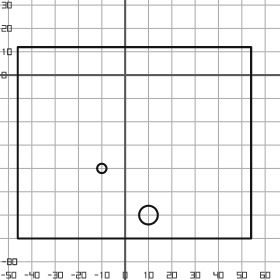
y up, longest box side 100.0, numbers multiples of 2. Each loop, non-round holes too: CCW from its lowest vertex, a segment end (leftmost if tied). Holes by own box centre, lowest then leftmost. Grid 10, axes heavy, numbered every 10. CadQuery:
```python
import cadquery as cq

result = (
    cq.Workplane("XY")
    .moveTo(-46.0, -70.0)
    .lineTo(54.0, -70.0)
    .lineTo(54.0, 12.0)
    .lineTo(-46.0, 12.0)
    .close()
    .moveTo(10.0, -60.0)
    .circle(4.0)
    .moveTo(-10.0, -40.0)
    .circle(2.0)
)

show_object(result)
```